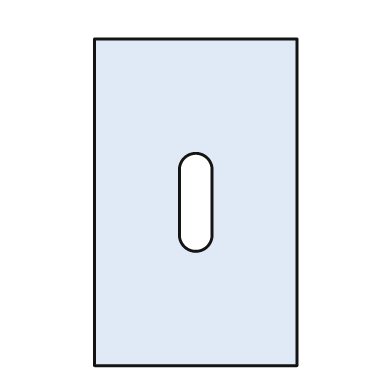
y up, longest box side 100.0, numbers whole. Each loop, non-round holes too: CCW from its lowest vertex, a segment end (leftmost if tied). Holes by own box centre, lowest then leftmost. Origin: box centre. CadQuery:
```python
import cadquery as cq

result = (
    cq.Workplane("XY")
    .moveTo(-31.0, -50.0)
    .lineTo(31.0, -50.0)
    .lineTo(31.0, 50.0)
    .lineTo(-31.0, 50.0)
    .close()
    .moveTo(-5.0, -10.0)
    .threePointArc((0.0, -15.0), (5.0, -10.0))
    .lineTo(5.0, 10.0)
    .threePointArc((0.0, 15.0), (-5.0, 10.0))
    .close()
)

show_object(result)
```